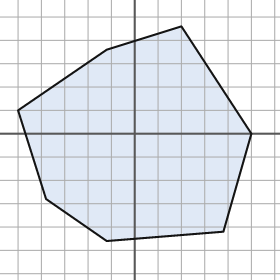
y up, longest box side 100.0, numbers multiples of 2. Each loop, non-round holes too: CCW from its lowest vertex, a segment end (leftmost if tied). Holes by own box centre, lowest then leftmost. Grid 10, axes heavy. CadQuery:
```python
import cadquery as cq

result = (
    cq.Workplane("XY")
    .moveTo(-12.0, -46.0)
    .lineTo(38.0, -42.0)
    .lineTo(50.0, 0.0)
    .lineTo(20.0, 46.0)
    .lineTo(-12.0, 36.0)
    .lineTo(-50.0, 10.0)
    .lineTo(-38.0, -28.0)
    .close()
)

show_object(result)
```